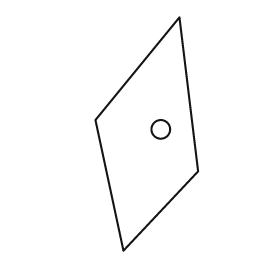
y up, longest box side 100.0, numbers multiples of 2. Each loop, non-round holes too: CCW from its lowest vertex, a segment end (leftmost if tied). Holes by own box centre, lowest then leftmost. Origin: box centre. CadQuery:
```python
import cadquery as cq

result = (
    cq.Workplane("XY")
    .moveTo(-10.0, -50.0)
    .lineTo(22.0, -16.0)
    .lineTo(14.0, 50.0)
    .lineTo(-22.0, 6.0)
    .close()
    .moveTo(6.0, 2.0)
    .circle(4.0)
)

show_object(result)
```